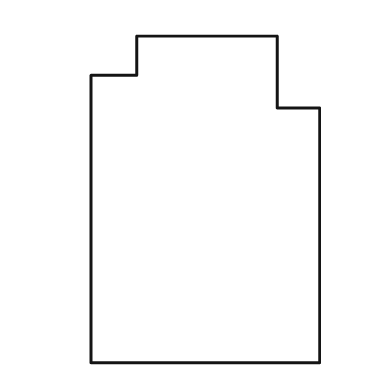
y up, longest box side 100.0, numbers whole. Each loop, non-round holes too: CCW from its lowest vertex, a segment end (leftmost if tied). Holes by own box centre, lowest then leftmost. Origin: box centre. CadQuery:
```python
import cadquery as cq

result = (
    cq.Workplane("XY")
    .moveTo(-35.0, -50.0)
    .lineTo(35.0, -50.0)
    .lineTo(35.0, 28.0)
    .lineTo(22.0, 28.0)
    .lineTo(22.0, 50.0)
    .lineTo(-21.0, 50.0)
    .lineTo(-21.0, 38.0)
    .lineTo(-35.0, 38.0)
    .close()
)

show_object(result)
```